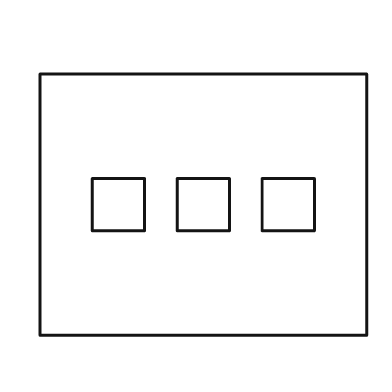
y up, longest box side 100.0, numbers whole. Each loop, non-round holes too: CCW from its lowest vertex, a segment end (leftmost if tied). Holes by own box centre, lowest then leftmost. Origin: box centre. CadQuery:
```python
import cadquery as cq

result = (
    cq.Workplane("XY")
    .moveTo(-50.0, -40.0)
    .lineTo(50.0, -40.0)
    .lineTo(50.0, 40.0)
    .lineTo(-50.0, 40.0)
    .close()
    .moveTo(-34.0, -8.0)
    .lineTo(-18.0, -8.0)
    .lineTo(-18.0, 8.0)
    .lineTo(-34.0, 8.0)
    .close()
    .moveTo(-8.0, -8.0)
    .lineTo(8.0, -8.0)
    .lineTo(8.0, 8.0)
    .lineTo(-8.0, 8.0)
    .close()
    .moveTo(18.0, -8.0)
    .lineTo(34.0, -8.0)
    .lineTo(34.0, 8.0)
    .lineTo(18.0, 8.0)
    .close()
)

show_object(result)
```